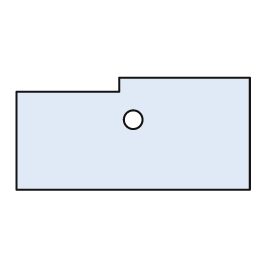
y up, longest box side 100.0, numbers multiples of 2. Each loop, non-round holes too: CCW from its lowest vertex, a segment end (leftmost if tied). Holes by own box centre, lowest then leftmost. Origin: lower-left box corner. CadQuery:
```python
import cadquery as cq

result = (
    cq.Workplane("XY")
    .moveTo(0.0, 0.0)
    .lineTo(100.0, 0.0)
    .lineTo(100.0, 48.0)
    .lineTo(44.0, 48.0)
    .lineTo(44.0, 42.0)
    .lineTo(0.0, 42.0)
    .close()
    .moveTo(50.0, 30.0)
    .circle(4.0)
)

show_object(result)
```